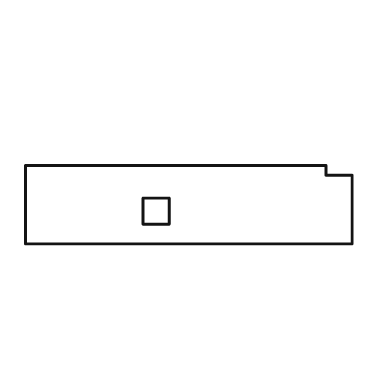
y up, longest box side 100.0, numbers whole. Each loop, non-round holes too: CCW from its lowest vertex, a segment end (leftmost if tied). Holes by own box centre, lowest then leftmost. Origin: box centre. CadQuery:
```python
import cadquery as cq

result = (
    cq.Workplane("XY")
    .moveTo(-50.0, -12.0)
    .lineTo(50.0, -12.0)
    .lineTo(50.0, 9.0)
    .lineTo(42.0, 9.0)
    .lineTo(42.0, 12.0)
    .lineTo(-50.0, 12.0)
    .close()
    .moveTo(-14.0, -6.0)
    .lineTo(-6.0, -6.0)
    .lineTo(-6.0, 2.0)
    .lineTo(-14.0, 2.0)
    .close()
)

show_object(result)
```